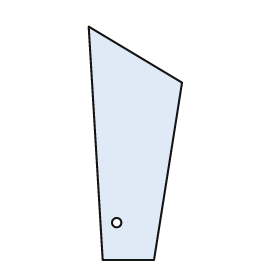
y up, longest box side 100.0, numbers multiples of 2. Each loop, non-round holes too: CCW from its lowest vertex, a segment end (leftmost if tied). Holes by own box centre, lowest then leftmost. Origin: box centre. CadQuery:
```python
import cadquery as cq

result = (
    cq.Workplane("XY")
    .moveTo(-14.0, -50.0)
    .lineTo(8.0, -50.0)
    .lineTo(20.0, 26.0)
    .lineTo(-20.0, 50.0)
    .close()
    .moveTo(-8.0, -34.0)
    .circle(2.0)
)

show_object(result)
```